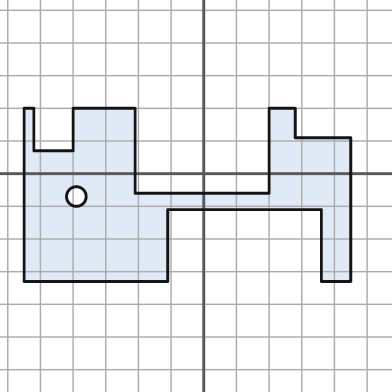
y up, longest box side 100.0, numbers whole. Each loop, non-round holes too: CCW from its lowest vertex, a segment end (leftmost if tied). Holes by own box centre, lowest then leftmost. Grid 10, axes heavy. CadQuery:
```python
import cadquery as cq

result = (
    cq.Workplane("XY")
    .moveTo(-55.0, -33.0)
    .lineTo(-11.0, -33.0)
    .lineTo(-11.0, -11.0)
    .lineTo(36.0, -11.0)
    .lineTo(36.0, -33.0)
    .lineTo(45.0, -33.0)
    .lineTo(45.0, 11.0)
    .lineTo(28.0, 11.0)
    .lineTo(28.0, 20.0)
    .lineTo(20.0, 20.0)
    .lineTo(20.0, -6.0)
    .lineTo(-21.0, -6.0)
    .lineTo(-21.0, 20.0)
    .lineTo(-40.0, 20.0)
    .lineTo(-40.0, 7.0)
    .lineTo(-52.0, 7.0)
    .lineTo(-52.0, 20.0)
    .lineTo(-55.0, 20.0)
    .close()
    .moveTo(-39.0, -7.0)
    .circle(3.0)
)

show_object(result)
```